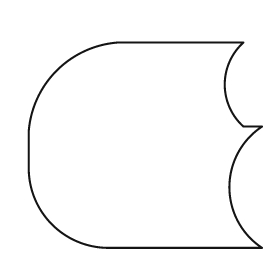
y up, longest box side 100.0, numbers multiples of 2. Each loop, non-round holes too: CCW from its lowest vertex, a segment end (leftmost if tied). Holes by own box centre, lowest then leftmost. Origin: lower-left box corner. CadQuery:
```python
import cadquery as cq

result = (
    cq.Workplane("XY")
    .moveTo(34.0, 0.0)
    .lineTo(100.0, 0.0)
    .threePointArc((86.0, 26.0), (100.0, 52.0))
    .lineTo(92.0, 52.0)
    .threePointArc((84.0, 70.0), (92.0, 88.0))
    .lineTo(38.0, 88.0)
    .threePointArc((12.0, 76.0), (0.0, 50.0))
    .lineTo(0.0, 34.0)
    .threePointArc((10.0, 10.0), (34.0, 0.0))
    .close()
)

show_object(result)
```